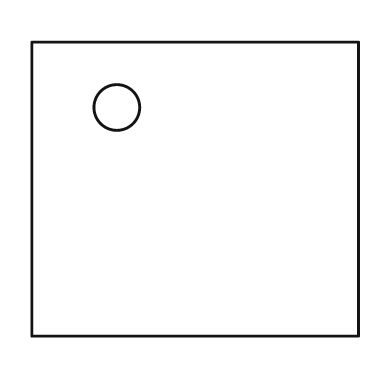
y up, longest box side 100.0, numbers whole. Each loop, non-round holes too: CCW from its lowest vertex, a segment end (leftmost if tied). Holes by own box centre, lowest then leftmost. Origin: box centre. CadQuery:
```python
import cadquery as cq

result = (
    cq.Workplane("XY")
    .moveTo(-50.0, -45.0)
    .lineTo(50.0, -45.0)
    .lineTo(50.0, 45.0)
    .lineTo(-50.0, 45.0)
    .close()
    .moveTo(-24.0, 25.0)
    .circle(7.0)
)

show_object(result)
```